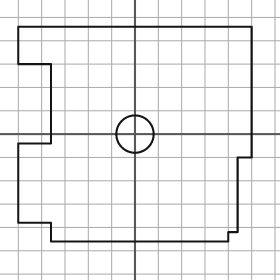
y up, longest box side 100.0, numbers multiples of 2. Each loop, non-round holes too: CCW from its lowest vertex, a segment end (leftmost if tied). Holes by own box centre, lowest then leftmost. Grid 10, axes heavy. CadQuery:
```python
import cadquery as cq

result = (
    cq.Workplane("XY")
    .moveTo(-36.0, -46.0)
    .lineTo(40.0, -46.0)
    .lineTo(40.0, -42.0)
    .lineTo(44.0, -42.0)
    .lineTo(44.0, -10.0)
    .lineTo(50.0, -10.0)
    .lineTo(50.0, 46.0)
    .lineTo(-50.0, 46.0)
    .lineTo(-50.0, 30.0)
    .lineTo(-36.0, 30.0)
    .lineTo(-36.0, -4.0)
    .lineTo(-50.0, -4.0)
    .lineTo(-50.0, -38.0)
    .lineTo(-36.0, -38.0)
    .close()
    .moveTo(0.0, 0.0)
    .circle(8.0)
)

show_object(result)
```